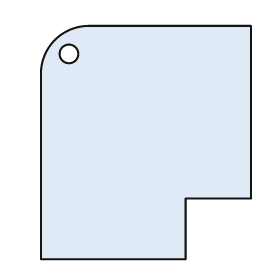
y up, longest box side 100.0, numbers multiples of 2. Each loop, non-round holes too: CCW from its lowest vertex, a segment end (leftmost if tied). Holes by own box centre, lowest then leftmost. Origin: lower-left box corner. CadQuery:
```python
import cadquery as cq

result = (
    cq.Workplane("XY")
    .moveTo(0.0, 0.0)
    .lineTo(62.0, 0.0)
    .lineTo(62.0, 26.0)
    .lineTo(90.0, 26.0)
    .lineTo(90.0, 100.0)
    .lineTo(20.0, 100.0)
    .threePointArc((6.0, 94.0), (0.0, 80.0))
    .close()
    .moveTo(12.0, 88.0)
    .circle(4.0)
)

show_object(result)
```